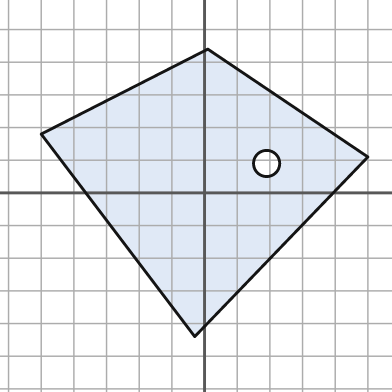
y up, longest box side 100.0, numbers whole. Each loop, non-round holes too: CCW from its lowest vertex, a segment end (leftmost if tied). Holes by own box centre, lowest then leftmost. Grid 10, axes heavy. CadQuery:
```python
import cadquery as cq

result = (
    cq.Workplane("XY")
    .moveTo(-3.0, -44.0)
    .lineTo(50.0, 11.0)
    .lineTo(1.0, 44.0)
    .lineTo(-50.0, 18.0)
    .close()
    .moveTo(19.0, 9.0)
    .circle(4.0)
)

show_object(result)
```